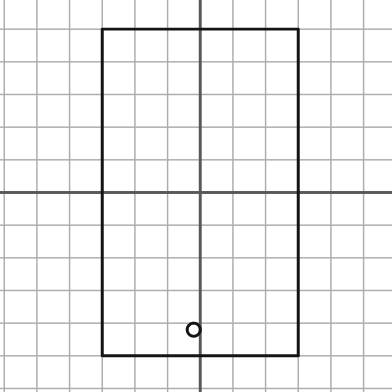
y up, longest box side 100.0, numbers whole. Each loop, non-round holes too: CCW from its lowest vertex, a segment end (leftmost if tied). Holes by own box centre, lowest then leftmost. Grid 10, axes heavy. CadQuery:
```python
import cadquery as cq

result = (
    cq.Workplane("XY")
    .moveTo(-30.0, -50.0)
    .lineTo(30.0, -50.0)
    .lineTo(30.0, 50.0)
    .lineTo(-30.0, 50.0)
    .close()
    .moveTo(-2.0, -42.0)
    .circle(2.0)
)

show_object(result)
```